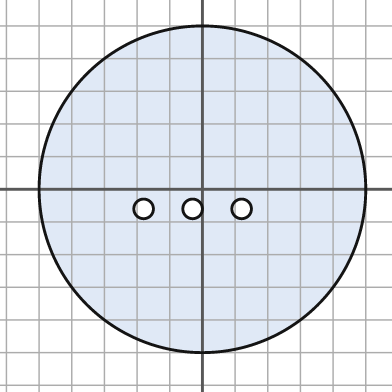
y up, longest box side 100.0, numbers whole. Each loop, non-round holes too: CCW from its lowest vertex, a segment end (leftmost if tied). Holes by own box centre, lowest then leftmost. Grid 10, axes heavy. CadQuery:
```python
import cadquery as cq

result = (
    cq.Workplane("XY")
    .moveTo(0.0, 0.0)
    .circle(50.0)
    .moveTo(-18.0, -6.0)
    .circle(3.0)
    .moveTo(-3.0, -6.0)
    .circle(3.0)
    .moveTo(12.0, -6.0)
    .circle(3.0)
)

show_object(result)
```